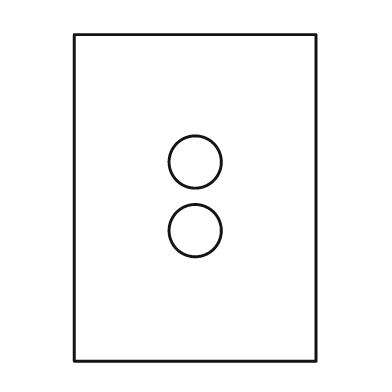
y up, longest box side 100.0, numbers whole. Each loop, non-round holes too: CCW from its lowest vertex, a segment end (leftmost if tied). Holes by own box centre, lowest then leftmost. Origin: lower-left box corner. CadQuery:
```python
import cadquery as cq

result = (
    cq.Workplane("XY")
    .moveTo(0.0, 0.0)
    .lineTo(74.0, 0.0)
    .lineTo(74.0, 100.0)
    .lineTo(0.0, 100.0)
    .close()
    .moveTo(37.0, 40.0)
    .circle(8.0)
    .moveTo(37.0, 61.0)
    .circle(8.0)
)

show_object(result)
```